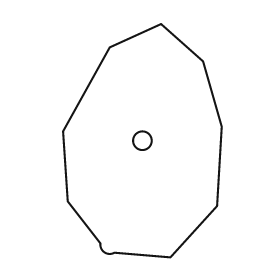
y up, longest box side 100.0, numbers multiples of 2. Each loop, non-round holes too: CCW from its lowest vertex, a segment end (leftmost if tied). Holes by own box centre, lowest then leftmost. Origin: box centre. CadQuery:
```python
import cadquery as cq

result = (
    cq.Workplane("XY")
    .moveTo(12.0, -50.0)
    .lineTo(32.0, -28.0)
    .lineTo(34.0, 6.0)
    .lineTo(26.0, 34.0)
    .lineTo(8.0, 50.0)
    .lineTo(-14.0, 40.0)
    .lineTo(-34.0, 4.0)
    .lineTo(-32.0, -26.0)
    .lineTo(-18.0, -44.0)
    .threePointArc((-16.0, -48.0), (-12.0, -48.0))
    .close()
    .moveTo(0.0, 0.0)
    .circle(4.0)
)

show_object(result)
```